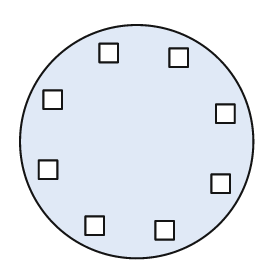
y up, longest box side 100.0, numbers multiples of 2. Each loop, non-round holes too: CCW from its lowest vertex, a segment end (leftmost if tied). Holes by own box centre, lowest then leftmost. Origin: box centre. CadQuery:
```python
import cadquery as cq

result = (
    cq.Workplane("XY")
    .moveTo(0.0, 0.0)
    .circle(50.0)
    .moveTo(8.0, -42.0)
    .lineTo(16.0, -42.0)
    .lineTo(16.0, -34.0)
    .lineTo(8.0, -34.0)
    .close()
    .moveTo(-22.0, -40.0)
    .lineTo(-14.0, -40.0)
    .lineTo(-14.0, -32.0)
    .lineTo(-22.0, -32.0)
    .close()
    .moveTo(32.0, -22.0)
    .lineTo(40.0, -22.0)
    .lineTo(40.0, -14.0)
    .lineTo(32.0, -14.0)
    .close()
    .moveTo(-42.0, -16.0)
    .lineTo(-34.0, -16.0)
    .lineTo(-34.0, -8.0)
    .lineTo(-42.0, -8.0)
    .close()
    .moveTo(34.0, 8.0)
    .lineTo(42.0, 8.0)
    .lineTo(42.0, 16.0)
    .lineTo(34.0, 16.0)
    .close()
    .moveTo(-40.0, 14.0)
    .lineTo(-32.0, 14.0)
    .lineTo(-32.0, 22.0)
    .lineTo(-40.0, 22.0)
    .close()
    .moveTo(14.0, 32.0)
    .lineTo(22.0, 32.0)
    .lineTo(22.0, 40.0)
    .lineTo(14.0, 40.0)
    .close()
    .moveTo(-16.0, 34.0)
    .lineTo(-8.0, 34.0)
    .lineTo(-8.0, 42.0)
    .lineTo(-16.0, 42.0)
    .close()
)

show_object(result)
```